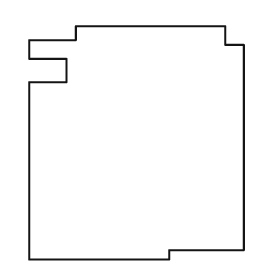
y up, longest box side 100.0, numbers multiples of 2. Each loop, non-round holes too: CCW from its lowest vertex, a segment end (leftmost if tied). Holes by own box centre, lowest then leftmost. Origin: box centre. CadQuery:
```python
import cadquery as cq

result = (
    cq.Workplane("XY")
    .moveTo(-46.0, -50.0)
    .lineTo(14.0, -50.0)
    .lineTo(14.0, -46.0)
    .lineTo(46.0, -46.0)
    .lineTo(46.0, 42.0)
    .lineTo(38.0, 42.0)
    .lineTo(38.0, 50.0)
    .lineTo(-26.0, 50.0)
    .lineTo(-26.0, 44.0)
    .lineTo(-46.0, 44.0)
    .lineTo(-46.0, 36.0)
    .lineTo(-30.0, 36.0)
    .lineTo(-30.0, 26.0)
    .lineTo(-46.0, 26.0)
    .close()
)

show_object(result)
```